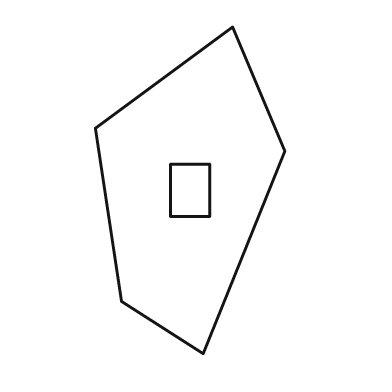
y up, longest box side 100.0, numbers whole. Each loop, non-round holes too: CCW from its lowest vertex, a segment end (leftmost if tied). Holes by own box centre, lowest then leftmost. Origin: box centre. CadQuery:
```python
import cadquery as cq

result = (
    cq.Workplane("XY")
    .moveTo(4.0, -50.0)
    .lineTo(29.0, 12.0)
    .lineTo(13.0, 50.0)
    .lineTo(-29.0, 19.0)
    .lineTo(-21.0, -34.0)
    .close()
    .moveTo(-6.0, -8.0)
    .lineTo(6.0, -8.0)
    .lineTo(6.0, 8.0)
    .lineTo(-6.0, 8.0)
    .close()
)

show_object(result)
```